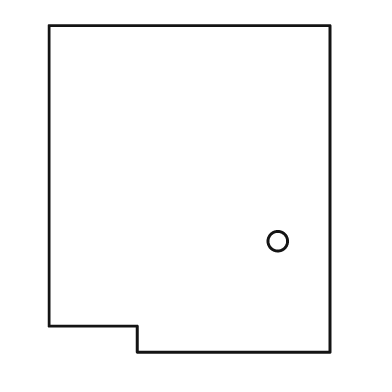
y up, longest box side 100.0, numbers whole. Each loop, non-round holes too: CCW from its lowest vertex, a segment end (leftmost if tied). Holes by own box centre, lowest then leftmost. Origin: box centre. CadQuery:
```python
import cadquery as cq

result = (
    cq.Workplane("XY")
    .moveTo(-16.0, -50.0)
    .lineTo(43.0, -50.0)
    .lineTo(43.0, 50.0)
    .lineTo(-43.0, 50.0)
    .lineTo(-43.0, -42.0)
    .lineTo(-16.0, -42.0)
    .close()
    .moveTo(27.0, -16.0)
    .circle(3.0)
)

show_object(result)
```